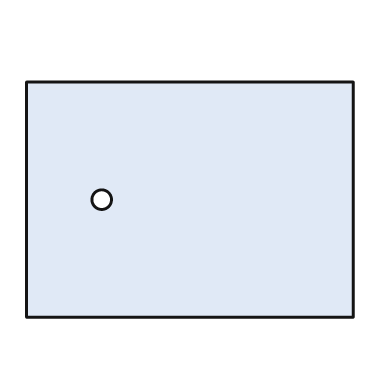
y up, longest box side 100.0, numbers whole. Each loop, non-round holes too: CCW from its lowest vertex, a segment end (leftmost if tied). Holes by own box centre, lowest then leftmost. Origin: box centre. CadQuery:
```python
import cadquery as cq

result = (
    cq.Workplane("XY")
    .moveTo(-50.0, -36.0)
    .lineTo(50.0, -36.0)
    .lineTo(50.0, 36.0)
    .lineTo(-50.0, 36.0)
    .close()
    .moveTo(-27.0, 0.0)
    .circle(3.0)
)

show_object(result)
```